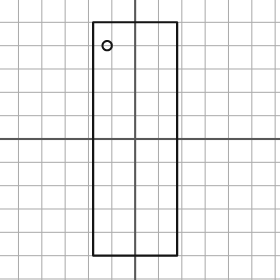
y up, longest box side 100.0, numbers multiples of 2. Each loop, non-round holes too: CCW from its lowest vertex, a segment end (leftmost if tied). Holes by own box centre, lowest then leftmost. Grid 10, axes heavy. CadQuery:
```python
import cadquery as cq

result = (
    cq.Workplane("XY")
    .moveTo(-18.0, -50.0)
    .lineTo(18.0, -50.0)
    .lineTo(18.0, 50.0)
    .lineTo(-18.0, 50.0)
    .close()
    .moveTo(-12.0, 40.0)
    .circle(2.0)
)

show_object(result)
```